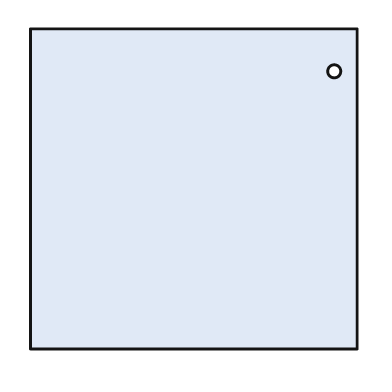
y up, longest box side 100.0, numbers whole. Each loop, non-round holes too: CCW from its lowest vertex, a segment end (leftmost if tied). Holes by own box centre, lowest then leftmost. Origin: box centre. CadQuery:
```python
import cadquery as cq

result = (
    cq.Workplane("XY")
    .moveTo(-50.0, -49.0)
    .lineTo(50.0, -49.0)
    .lineTo(50.0, 49.0)
    .lineTo(-50.0, 49.0)
    .close()
    .moveTo(43.0, 36.0)
    .circle(2.0)
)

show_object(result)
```